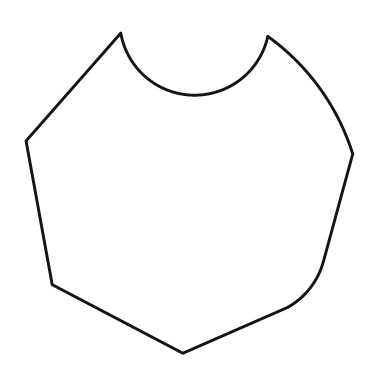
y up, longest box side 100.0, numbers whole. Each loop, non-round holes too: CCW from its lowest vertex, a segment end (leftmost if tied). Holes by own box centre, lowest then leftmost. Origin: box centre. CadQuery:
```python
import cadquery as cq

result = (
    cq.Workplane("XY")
    .moveTo(-2.0, -49.0)
    .lineTo(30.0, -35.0)
    .threePointArc((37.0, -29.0), (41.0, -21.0))
    .lineTo(50.0, 12.0)
    .threePointArc((40.0, 32.0), (24.0, 48.0))
    .threePointArc((1.0, 30.0), (-21.0, 49.0))
    .lineTo(-50.0, 16.0)
    .lineTo(-42.0, -28.0)
    .close()
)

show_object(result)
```